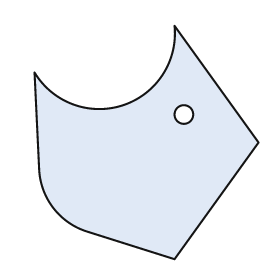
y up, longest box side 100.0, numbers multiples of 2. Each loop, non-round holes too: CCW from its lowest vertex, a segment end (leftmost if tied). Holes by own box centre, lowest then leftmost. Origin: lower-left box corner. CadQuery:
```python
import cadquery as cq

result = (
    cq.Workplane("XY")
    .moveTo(60.0, 0.0)
    .lineTo(96.0, 50.0)
    .lineTo(60.0, 100.0)
    .threePointArc((38.0, 66.0), (0.0, 80.0))
    .lineTo(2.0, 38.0)
    .threePointArc((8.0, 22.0), (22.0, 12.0))
    .close()
    .moveTo(64.0, 62.0)
    .circle(4.0)
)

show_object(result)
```